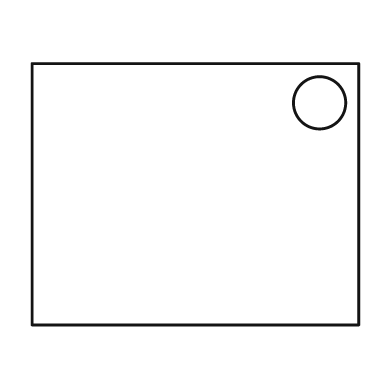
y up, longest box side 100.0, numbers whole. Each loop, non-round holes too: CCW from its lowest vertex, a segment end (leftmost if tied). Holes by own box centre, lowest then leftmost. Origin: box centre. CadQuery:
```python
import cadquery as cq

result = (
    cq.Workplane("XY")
    .moveTo(-50.0, -40.0)
    .lineTo(50.0, -40.0)
    .lineTo(50.0, 40.0)
    .lineTo(-50.0, 40.0)
    .close()
    .moveTo(38.0, 28.0)
    .circle(8.0)
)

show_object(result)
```